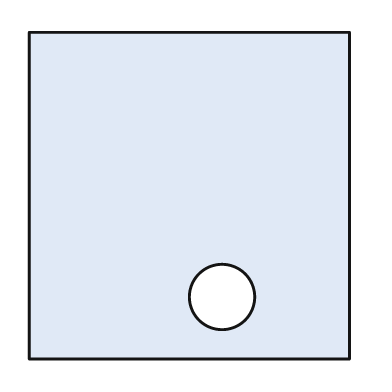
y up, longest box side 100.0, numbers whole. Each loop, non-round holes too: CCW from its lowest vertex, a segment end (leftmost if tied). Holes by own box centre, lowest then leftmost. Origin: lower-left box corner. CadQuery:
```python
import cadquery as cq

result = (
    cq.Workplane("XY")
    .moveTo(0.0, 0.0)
    .lineTo(98.0, 0.0)
    .lineTo(98.0, 100.0)
    .lineTo(0.0, 100.0)
    .close()
    .moveTo(59.0, 19.0)
    .circle(10.0)
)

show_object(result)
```